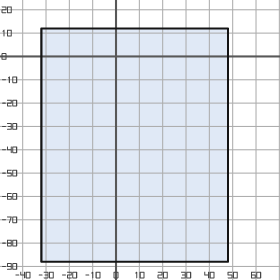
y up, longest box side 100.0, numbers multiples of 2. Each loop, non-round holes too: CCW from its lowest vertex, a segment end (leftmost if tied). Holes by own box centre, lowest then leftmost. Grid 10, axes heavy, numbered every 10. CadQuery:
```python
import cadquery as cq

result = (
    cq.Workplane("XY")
    .moveTo(-32.0, -88.0)
    .lineTo(48.0, -88.0)
    .lineTo(48.0, 12.0)
    .lineTo(-32.0, 12.0)
    .close()
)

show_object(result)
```